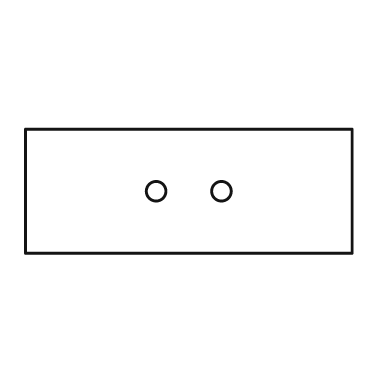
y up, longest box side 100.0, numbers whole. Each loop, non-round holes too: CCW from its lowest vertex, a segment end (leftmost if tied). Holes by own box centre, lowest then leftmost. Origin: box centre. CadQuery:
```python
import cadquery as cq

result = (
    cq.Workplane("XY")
    .moveTo(-50.0, -19.0)
    .lineTo(50.0, -19.0)
    .lineTo(50.0, 19.0)
    .lineTo(-50.0, 19.0)
    .close()
    .moveTo(-10.0, 0.0)
    .circle(3.0)
    .moveTo(10.0, 0.0)
    .circle(3.0)
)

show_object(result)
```